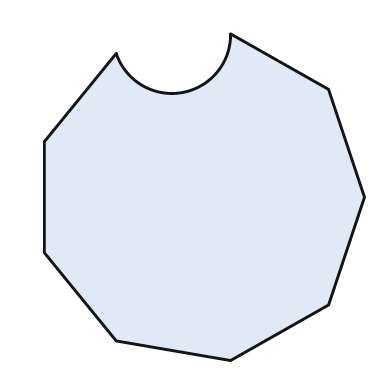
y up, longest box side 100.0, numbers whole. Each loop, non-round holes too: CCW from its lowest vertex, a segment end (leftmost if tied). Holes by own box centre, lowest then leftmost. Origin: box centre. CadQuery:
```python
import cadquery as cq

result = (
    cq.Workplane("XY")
    .moveTo(8.0, -50.0)
    .lineTo(38.0, -33.0)
    .lineTo(49.0, 0.0)
    .lineTo(38.0, 33.0)
    .lineTo(8.0, 50.0)
    .threePointArc((-7.0, 32.0), (-27.0, 44.0))
    .lineTo(-49.0, 17.0)
    .lineTo(-49.0, -17.0)
    .lineTo(-27.0, -44.0)
    .close()
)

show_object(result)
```